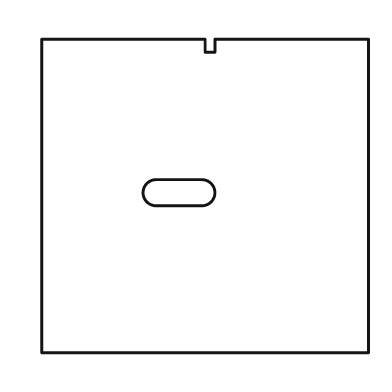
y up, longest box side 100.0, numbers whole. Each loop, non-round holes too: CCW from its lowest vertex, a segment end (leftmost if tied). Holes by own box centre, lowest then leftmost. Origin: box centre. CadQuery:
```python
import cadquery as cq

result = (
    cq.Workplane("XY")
    .moveTo(-50.0, -48.0)
    .lineTo(50.0, -48.0)
    .lineTo(50.0, 48.0)
    .lineTo(3.0, 48.0)
    .lineTo(3.0, 44.0)
    .lineTo(0.0, 44.0)
    .lineTo(0.0, 48.0)
    .lineTo(-50.0, 48.0)
    .close()
    .moveTo(-15.0, -3.0)
    .lineTo(-1.0, -3.0)
    .threePointArc((3.0, 1.0), (-1.0, 5.0))
    .lineTo(-15.0, 5.0)
    .threePointArc((-19.0, 1.0), (-15.0, -3.0))
    .close()
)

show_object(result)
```